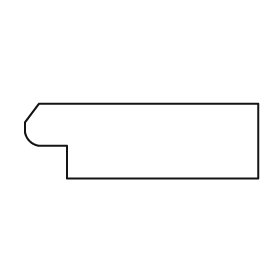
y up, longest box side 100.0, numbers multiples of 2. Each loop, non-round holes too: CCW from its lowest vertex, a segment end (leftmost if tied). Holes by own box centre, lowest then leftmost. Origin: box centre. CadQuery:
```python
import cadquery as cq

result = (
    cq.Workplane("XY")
    .moveTo(-32.0, -16.0)
    .lineTo(50.0, -16.0)
    .lineTo(50.0, 16.0)
    .lineTo(-44.0, 16.0)
    .lineTo(-50.0, 8.0)
    .lineTo(-50.0, 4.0)
    .threePointArc((-48.0, 0.0), (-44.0, -2.0))
    .lineTo(-32.0, -2.0)
    .close()
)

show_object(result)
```